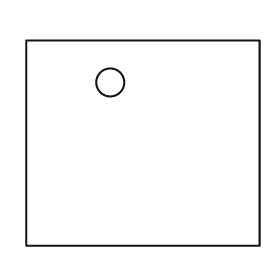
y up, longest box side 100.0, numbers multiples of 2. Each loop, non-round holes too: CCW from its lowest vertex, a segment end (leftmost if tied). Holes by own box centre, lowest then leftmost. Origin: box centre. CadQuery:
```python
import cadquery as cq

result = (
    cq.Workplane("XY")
    .moveTo(-50.0, -44.0)
    .lineTo(50.0, -44.0)
    .lineTo(50.0, 44.0)
    .lineTo(-50.0, 44.0)
    .close()
    .moveTo(-14.0, 26.0)
    .circle(6.0)
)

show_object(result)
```